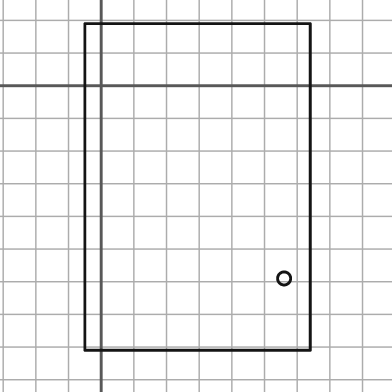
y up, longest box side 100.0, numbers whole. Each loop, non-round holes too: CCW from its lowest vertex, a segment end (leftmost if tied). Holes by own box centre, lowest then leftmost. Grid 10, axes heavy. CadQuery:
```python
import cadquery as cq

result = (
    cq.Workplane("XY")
    .moveTo(-5.0, -81.0)
    .lineTo(64.0, -81.0)
    .lineTo(64.0, 19.0)
    .lineTo(-5.0, 19.0)
    .close()
    .moveTo(56.0, -59.0)
    .circle(2.0)
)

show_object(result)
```